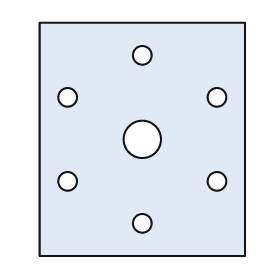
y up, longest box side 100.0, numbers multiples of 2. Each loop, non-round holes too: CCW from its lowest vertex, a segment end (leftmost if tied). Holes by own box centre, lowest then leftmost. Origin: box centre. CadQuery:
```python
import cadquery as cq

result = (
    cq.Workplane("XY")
    .moveTo(-44.0, -50.0)
    .lineTo(44.0, -50.0)
    .lineTo(44.0, 50.0)
    .lineTo(-44.0, 50.0)
    .close()
    .moveTo(0.0, -36.0)
    .circle(4.0)
    .moveTo(-32.0, -18.0)
    .circle(4.0)
    .moveTo(32.0, -18.0)
    .circle(4.0)
    .moveTo(0.0, 0.0)
    .circle(8.0)
    .moveTo(-32.0, 18.0)
    .circle(4.0)
    .moveTo(32.0, 18.0)
    .circle(4.0)
    .moveTo(0.0, 36.0)
    .circle(4.0)
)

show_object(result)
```